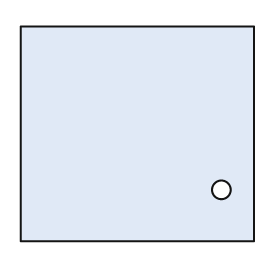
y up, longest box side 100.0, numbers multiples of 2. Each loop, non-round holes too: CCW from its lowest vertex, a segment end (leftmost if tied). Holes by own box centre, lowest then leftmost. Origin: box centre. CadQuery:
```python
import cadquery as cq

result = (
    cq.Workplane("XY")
    .moveTo(-50.0, -46.0)
    .lineTo(50.0, -46.0)
    .lineTo(50.0, 46.0)
    .lineTo(-50.0, 46.0)
    .close()
    .moveTo(36.0, -24.0)
    .circle(4.0)
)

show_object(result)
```